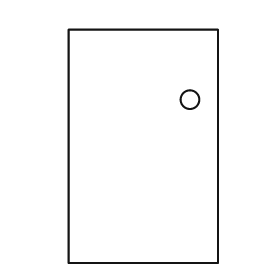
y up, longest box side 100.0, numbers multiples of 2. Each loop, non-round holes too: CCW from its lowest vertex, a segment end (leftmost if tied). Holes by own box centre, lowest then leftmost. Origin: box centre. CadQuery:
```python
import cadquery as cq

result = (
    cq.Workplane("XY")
    .moveTo(-32.0, -50.0)
    .lineTo(32.0, -50.0)
    .lineTo(32.0, 50.0)
    .lineTo(-32.0, 50.0)
    .close()
    .moveTo(20.0, 20.0)
    .circle(4.0)
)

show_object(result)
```